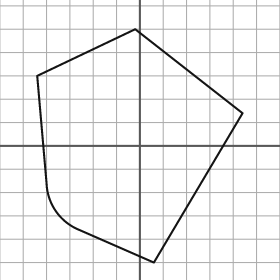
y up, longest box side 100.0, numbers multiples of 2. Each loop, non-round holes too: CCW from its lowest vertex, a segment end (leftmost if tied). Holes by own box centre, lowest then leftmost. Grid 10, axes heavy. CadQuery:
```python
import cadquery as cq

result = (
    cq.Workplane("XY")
    .moveTo(6.0, -50.0)
    .lineTo(44.0, 14.0)
    .lineTo(-2.0, 50.0)
    .lineTo(-44.0, 30.0)
    .lineTo(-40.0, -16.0)
    .threePointArc((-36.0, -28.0), (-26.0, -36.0))
    .close()
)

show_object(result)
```